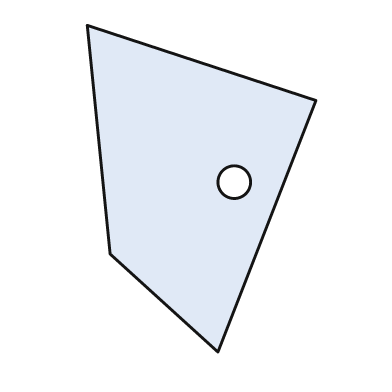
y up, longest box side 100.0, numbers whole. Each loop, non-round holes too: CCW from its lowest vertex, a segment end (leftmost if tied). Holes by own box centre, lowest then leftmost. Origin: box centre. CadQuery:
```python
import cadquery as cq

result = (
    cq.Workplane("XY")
    .moveTo(5.0, -50.0)
    .lineTo(35.0, 27.0)
    .lineTo(-35.0, 50.0)
    .lineTo(-28.0, -20.0)
    .close()
    .moveTo(10.0, 2.0)
    .circle(5.0)
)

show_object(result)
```